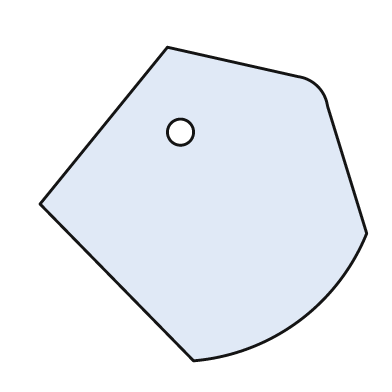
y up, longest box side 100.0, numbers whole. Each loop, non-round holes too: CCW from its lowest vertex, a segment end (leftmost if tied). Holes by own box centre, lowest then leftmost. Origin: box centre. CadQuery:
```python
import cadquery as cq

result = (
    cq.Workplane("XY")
    .moveTo(-3.0, -48.0)
    .threePointArc((29.0, -36.0), (50.0, -9.0))
    .lineTo(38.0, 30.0)
    .threePointArc((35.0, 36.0), (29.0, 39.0))
    .lineTo(-11.0, 48.0)
    .lineTo(-50.0, 0.0)
    .close()
    .moveTo(-7.0, 22.0)
    .circle(4.0)
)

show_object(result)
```